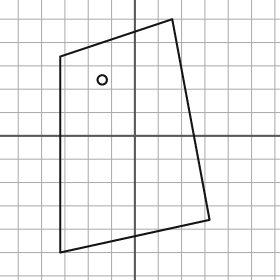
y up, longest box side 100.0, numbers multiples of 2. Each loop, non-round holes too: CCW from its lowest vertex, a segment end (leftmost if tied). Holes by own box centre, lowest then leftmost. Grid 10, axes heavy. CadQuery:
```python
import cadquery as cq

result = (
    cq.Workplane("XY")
    .moveTo(-32.0, -50.0)
    .lineTo(32.0, -36.0)
    .lineTo(16.0, 50.0)
    .lineTo(-32.0, 34.0)
    .close()
    .moveTo(-14.0, 24.0)
    .circle(2.0)
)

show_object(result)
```